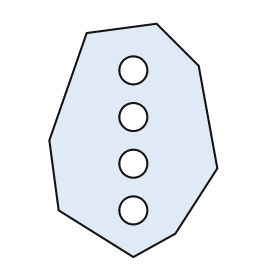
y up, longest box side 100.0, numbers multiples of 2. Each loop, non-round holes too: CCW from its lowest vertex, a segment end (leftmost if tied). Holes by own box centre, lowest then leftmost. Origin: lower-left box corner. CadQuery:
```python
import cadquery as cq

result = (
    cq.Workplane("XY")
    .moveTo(36.0, 0.0)
    .lineTo(54.0, 10.0)
    .lineTo(72.0, 38.0)
    .lineTo(64.0, 82.0)
    .lineTo(46.0, 100.0)
    .lineTo(16.0, 96.0)
    .lineTo(0.0, 50.0)
    .lineTo(4.0, 20.0)
    .close()
    .moveTo(36.0, 20.0)
    .circle(6.0)
    .moveTo(36.0, 40.0)
    .circle(6.0)
    .moveTo(36.0, 60.0)
    .circle(6.0)
    .moveTo(36.0, 80.0)
    .circle(6.0)
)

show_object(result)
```